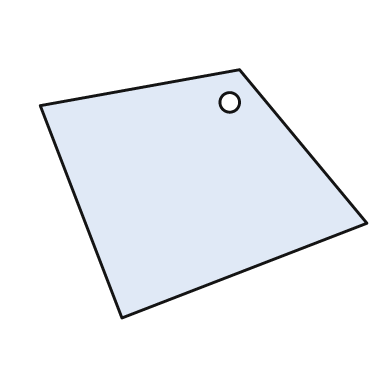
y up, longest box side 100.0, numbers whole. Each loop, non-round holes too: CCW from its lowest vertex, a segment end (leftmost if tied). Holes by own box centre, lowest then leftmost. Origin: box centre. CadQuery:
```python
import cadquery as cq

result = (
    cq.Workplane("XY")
    .moveTo(-25.0, -38.0)
    .lineTo(50.0, -9.0)
    .lineTo(11.0, 38.0)
    .lineTo(-50.0, 27.0)
    .close()
    .moveTo(8.0, 28.0)
    .circle(3.0)
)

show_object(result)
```